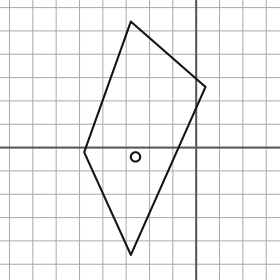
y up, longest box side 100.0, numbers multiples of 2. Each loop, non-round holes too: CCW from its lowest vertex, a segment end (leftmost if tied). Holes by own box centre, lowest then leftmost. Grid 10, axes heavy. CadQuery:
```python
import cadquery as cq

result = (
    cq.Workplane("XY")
    .moveTo(-28.0, -46.0)
    .lineTo(4.0, 26.0)
    .lineTo(-28.0, 54.0)
    .lineTo(-48.0, -2.0)
    .close()
    .moveTo(-26.0, -4.0)
    .circle(2.0)
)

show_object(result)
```